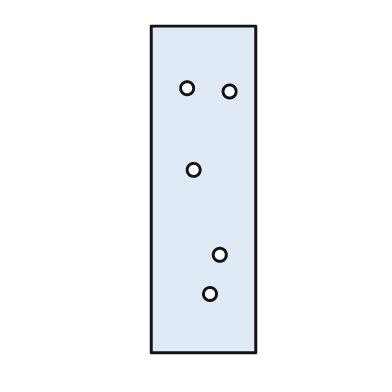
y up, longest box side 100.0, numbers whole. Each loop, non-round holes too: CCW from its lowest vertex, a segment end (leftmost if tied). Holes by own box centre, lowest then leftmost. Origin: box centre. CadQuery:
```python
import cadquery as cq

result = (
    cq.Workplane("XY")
    .moveTo(-16.0, -50.0)
    .lineTo(16.0, -50.0)
    .lineTo(16.0, 50.0)
    .lineTo(-16.0, 50.0)
    .close()
    .moveTo(2.0, -32.0)
    .circle(2.0)
    .moveTo(5.0, -20.0)
    .circle(2.0)
    .moveTo(-3.0, 6.0)
    .circle(2.0)
    .moveTo(8.0, 30.0)
    .circle(2.0)
    .moveTo(-5.0, 31.0)
    .circle(2.0)
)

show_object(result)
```